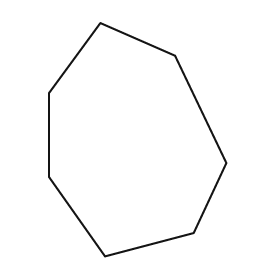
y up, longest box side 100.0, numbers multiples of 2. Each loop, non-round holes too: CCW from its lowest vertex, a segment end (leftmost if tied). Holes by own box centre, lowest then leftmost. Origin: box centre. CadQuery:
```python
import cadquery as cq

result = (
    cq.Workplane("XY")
    .moveTo(-14.0, -50.0)
    .lineTo(24.0, -40.0)
    .lineTo(38.0, -10.0)
    .lineTo(16.0, 36.0)
    .lineTo(-16.0, 50.0)
    .lineTo(-38.0, 20.0)
    .lineTo(-38.0, -16.0)
    .close()
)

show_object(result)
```